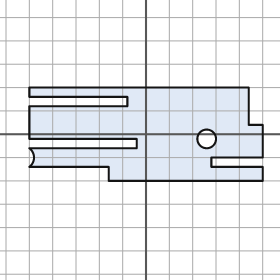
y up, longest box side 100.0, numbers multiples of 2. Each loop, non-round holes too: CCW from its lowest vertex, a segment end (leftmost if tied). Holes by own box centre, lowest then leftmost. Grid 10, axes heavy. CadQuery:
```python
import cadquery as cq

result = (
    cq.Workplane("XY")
    .moveTo(-16.0, -20.0)
    .lineTo(50.0, -20.0)
    .lineTo(50.0, -14.0)
    .lineTo(28.0, -14.0)
    .lineTo(28.0, -10.0)
    .lineTo(50.0, -10.0)
    .lineTo(50.0, 4.0)
    .lineTo(44.0, 4.0)
    .lineTo(44.0, 20.0)
    .lineTo(-50.0, 20.0)
    .lineTo(-50.0, 16.0)
    .lineTo(-8.0, 16.0)
    .lineTo(-8.0, 12.0)
    .lineTo(-50.0, 12.0)
    .lineTo(-50.0, -2.0)
    .lineTo(-4.0, -2.0)
    .lineTo(-4.0, -6.0)
    .lineTo(-50.0, -6.0)
    .threePointArc((-48.0, -10.0), (-50.0, -14.0))
    .lineTo(-16.0, -14.0)
    .close()
    .moveTo(26.0, -2.0)
    .circle(4.0)
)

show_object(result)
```